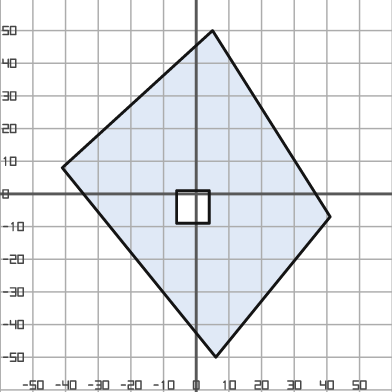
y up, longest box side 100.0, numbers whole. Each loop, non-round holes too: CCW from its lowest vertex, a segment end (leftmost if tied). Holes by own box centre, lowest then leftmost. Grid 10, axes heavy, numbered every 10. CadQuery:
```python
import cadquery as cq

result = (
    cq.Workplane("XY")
    .moveTo(6.0, -50.0)
    .lineTo(41.0, -7.0)
    .lineTo(5.0, 50.0)
    .lineTo(-41.0, 8.0)
    .close()
    .moveTo(-6.0, -9.0)
    .lineTo(4.0, -9.0)
    .lineTo(4.0, 1.0)
    .lineTo(-6.0, 1.0)
    .close()
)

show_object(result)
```